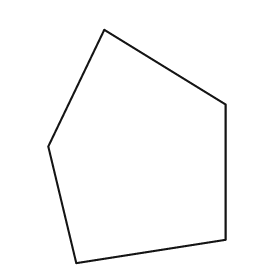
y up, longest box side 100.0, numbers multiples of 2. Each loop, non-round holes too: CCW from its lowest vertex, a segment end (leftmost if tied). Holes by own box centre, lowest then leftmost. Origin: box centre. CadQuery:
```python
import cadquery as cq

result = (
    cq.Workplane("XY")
    .moveTo(-26.0, -50.0)
    .lineTo(38.0, -40.0)
    .lineTo(38.0, 18.0)
    .lineTo(-14.0, 50.0)
    .lineTo(-38.0, 0.0)
    .close()
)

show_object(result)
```